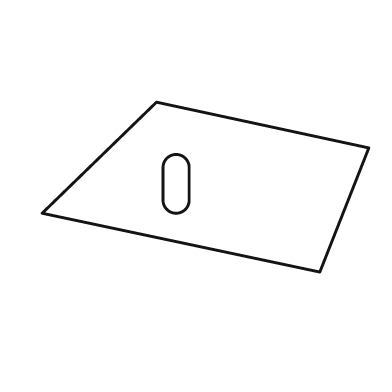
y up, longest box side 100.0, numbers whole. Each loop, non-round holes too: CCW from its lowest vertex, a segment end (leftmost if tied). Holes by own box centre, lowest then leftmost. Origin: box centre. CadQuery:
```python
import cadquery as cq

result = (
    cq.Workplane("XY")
    .moveTo(35.0, -26.0)
    .lineTo(50.0, 12.0)
    .lineTo(-15.0, 26.0)
    .lineTo(-50.0, -8.0)
    .close()
    .moveTo(-13.0, -4.0)
    .threePointArc((-9.0, -8.0), (-5.0, -4.0))
    .lineTo(-5.0, 6.0)
    .threePointArc((-9.0, 10.0), (-13.0, 6.0))
    .close()
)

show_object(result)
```